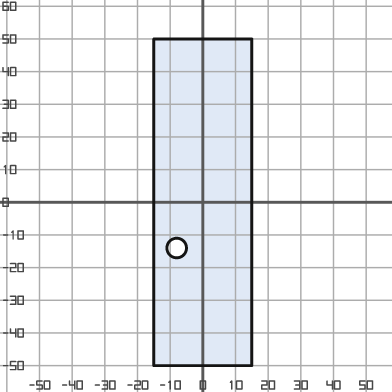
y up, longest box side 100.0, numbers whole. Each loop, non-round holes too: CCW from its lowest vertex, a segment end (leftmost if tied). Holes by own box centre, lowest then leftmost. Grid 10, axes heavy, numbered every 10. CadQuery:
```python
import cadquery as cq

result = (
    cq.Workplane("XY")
    .moveTo(-15.0, -50.0)
    .lineTo(15.0, -50.0)
    .lineTo(15.0, 50.0)
    .lineTo(-15.0, 50.0)
    .close()
    .moveTo(-8.0, -14.0)
    .circle(3.0)
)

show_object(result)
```